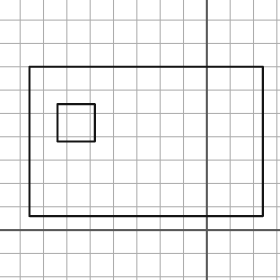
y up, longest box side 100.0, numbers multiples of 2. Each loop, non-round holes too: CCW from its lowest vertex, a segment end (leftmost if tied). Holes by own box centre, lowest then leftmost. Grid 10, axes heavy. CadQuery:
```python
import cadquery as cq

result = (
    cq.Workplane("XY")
    .moveTo(-76.0, 6.0)
    .lineTo(24.0, 6.0)
    .lineTo(24.0, 70.0)
    .lineTo(-76.0, 70.0)
    .close()
    .moveTo(-64.0, 38.0)
    .lineTo(-48.0, 38.0)
    .lineTo(-48.0, 54.0)
    .lineTo(-64.0, 54.0)
    .close()
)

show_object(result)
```